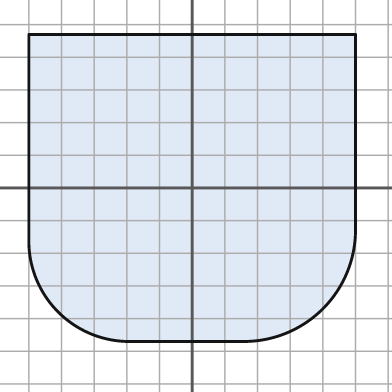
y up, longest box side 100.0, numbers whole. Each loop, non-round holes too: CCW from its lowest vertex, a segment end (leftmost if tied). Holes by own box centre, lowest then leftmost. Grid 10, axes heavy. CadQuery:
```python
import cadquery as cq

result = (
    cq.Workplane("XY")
    .moveTo(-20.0, -47.0)
    .lineTo(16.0, -47.0)
    .threePointArc((40.0, -37.0), (50.0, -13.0))
    .lineTo(50.0, 47.0)
    .lineTo(-50.0, 47.0)
    .lineTo(-50.0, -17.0)
    .threePointArc((-41.0, -38.0), (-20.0, -47.0))
    .close()
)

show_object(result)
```